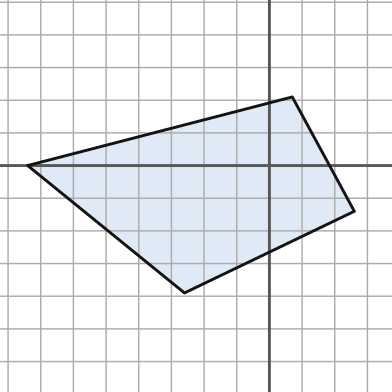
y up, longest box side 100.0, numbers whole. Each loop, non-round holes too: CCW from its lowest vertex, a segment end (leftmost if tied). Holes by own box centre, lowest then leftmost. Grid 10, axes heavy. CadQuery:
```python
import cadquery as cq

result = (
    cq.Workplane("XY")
    .moveTo(-26.0, -39.0)
    .lineTo(26.0, -14.0)
    .lineTo(7.0, 21.0)
    .lineTo(-74.0, 0.0)
    .close()
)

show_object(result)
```